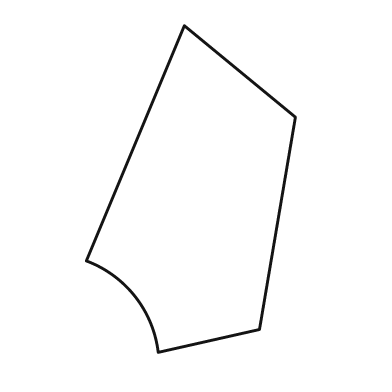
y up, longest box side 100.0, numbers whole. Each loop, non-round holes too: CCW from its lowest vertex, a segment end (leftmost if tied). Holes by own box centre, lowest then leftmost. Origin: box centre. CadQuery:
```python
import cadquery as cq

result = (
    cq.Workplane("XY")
    .moveTo(-10.0, -50.0)
    .lineTo(21.0, -43.0)
    .lineTo(32.0, 22.0)
    .lineTo(-2.0, 50.0)
    .lineTo(-32.0, -22.0)
    .threePointArc((-17.0, -33.0), (-10.0, -50.0))
    .close()
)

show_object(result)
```